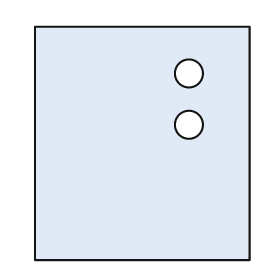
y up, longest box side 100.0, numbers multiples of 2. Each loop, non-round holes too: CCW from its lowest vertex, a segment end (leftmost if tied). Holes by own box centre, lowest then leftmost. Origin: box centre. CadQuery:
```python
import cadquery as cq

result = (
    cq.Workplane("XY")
    .moveTo(-46.0, -50.0)
    .lineTo(46.0, -50.0)
    .lineTo(46.0, 50.0)
    .lineTo(-46.0, 50.0)
    .close()
    .moveTo(20.0, 8.0)
    .circle(6.0)
    .moveTo(20.0, 30.0)
    .circle(6.0)
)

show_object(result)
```